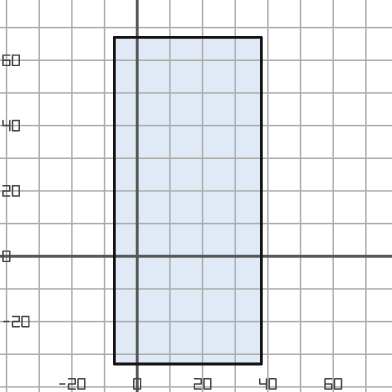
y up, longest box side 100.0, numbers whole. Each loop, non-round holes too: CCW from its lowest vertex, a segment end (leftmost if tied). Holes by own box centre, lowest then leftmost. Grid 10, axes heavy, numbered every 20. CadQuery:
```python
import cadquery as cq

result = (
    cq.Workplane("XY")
    .moveTo(-7.0, -33.0)
    .lineTo(38.0, -33.0)
    .lineTo(38.0, 67.0)
    .lineTo(-7.0, 67.0)
    .close()
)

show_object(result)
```